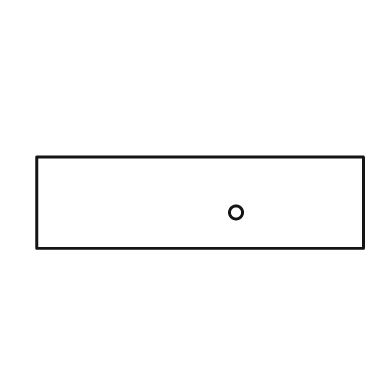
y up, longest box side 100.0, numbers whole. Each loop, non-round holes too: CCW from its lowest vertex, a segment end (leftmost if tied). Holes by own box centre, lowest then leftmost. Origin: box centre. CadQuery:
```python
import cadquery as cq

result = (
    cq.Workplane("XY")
    .moveTo(-50.0, -14.0)
    .lineTo(50.0, -14.0)
    .lineTo(50.0, 14.0)
    .lineTo(-50.0, 14.0)
    .close()
    .moveTo(11.0, -3.0)
    .circle(2.0)
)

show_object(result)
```